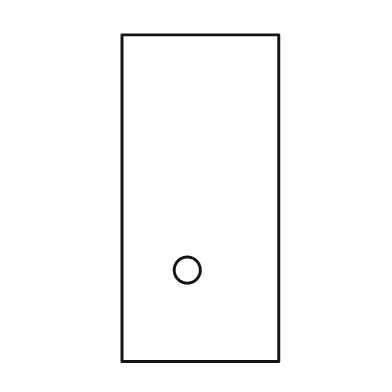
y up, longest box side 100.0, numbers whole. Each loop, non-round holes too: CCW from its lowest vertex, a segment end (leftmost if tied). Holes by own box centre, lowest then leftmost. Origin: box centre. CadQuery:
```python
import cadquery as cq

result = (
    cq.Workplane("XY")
    .moveTo(-24.0, -50.0)
    .lineTo(24.0, -50.0)
    .lineTo(24.0, 50.0)
    .lineTo(-24.0, 50.0)
    .close()
    .moveTo(-4.0, -22.0)
    .circle(4.0)
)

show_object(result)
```